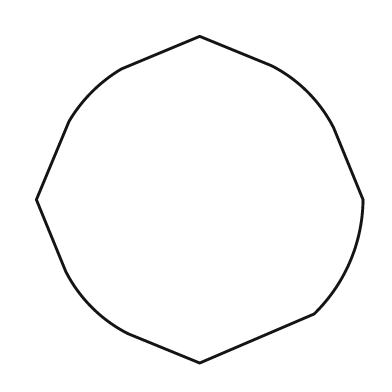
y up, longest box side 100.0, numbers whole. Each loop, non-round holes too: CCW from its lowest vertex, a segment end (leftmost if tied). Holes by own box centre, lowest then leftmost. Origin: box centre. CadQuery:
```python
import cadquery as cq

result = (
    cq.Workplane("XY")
    .moveTo(0.0, -50.0)
    .lineTo(35.0, -35.0)
    .threePointArc((46.0, -19.0), (50.0, 0.0))
    .lineTo(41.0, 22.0)
    .threePointArc((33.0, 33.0), (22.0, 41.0))
    .lineTo(0.0, 50.0)
    .lineTo(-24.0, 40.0)
    .threePointArc((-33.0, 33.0), (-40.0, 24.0))
    .lineTo(-50.0, 0.0)
    .lineTo(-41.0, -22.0)
    .threePointArc((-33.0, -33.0), (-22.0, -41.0))
    .close()
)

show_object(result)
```